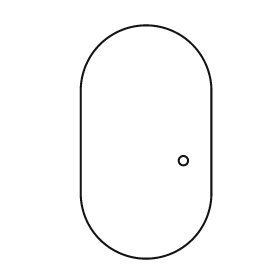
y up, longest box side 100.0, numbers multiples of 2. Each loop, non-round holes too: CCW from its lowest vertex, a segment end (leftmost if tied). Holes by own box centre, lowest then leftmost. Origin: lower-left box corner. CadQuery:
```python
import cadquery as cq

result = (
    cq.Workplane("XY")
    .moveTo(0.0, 28.0)
    .threePointArc((28.0, 0.0), (56.0, 28.0))
    .lineTo(56.0, 72.0)
    .threePointArc((28.0, 100.0), (0.0, 72.0))
    .close()
    .moveTo(44.0, 42.0)
    .circle(2.0)
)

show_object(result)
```